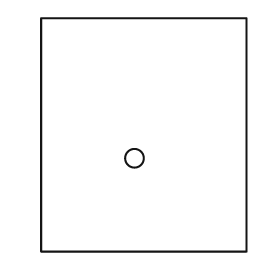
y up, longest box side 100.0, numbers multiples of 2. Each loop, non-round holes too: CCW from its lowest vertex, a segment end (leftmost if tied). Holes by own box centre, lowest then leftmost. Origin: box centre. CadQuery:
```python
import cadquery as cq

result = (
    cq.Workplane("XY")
    .moveTo(-44.0, -50.0)
    .lineTo(44.0, -50.0)
    .lineTo(44.0, 50.0)
    .lineTo(-44.0, 50.0)
    .close()
    .moveTo(-4.0, -10.0)
    .circle(4.0)
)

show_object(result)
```